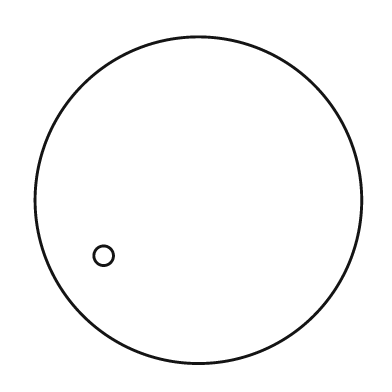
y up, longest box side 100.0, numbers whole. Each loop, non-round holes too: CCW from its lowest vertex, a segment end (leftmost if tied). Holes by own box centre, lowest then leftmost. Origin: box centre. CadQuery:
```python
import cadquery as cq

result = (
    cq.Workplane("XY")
    .moveTo(0.0, 0.0)
    .circle(50.0)
    .moveTo(-29.0, -17.0)
    .circle(3.0)
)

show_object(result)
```